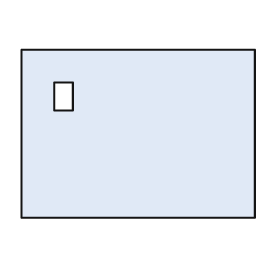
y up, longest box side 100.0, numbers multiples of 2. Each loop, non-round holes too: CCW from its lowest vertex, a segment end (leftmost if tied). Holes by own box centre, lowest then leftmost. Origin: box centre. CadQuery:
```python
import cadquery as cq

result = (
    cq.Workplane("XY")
    .moveTo(-50.0, -36.0)
    .lineTo(50.0, -36.0)
    .lineTo(50.0, 36.0)
    .lineTo(-50.0, 36.0)
    .close()
    .moveTo(-36.0, 10.0)
    .lineTo(-28.0, 10.0)
    .lineTo(-28.0, 22.0)
    .lineTo(-36.0, 22.0)
    .close()
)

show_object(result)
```